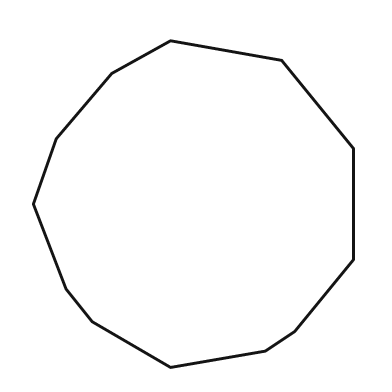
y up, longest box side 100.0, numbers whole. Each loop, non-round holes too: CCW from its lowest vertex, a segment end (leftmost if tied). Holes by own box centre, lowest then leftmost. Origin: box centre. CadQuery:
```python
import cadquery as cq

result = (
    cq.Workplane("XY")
    .moveTo(-7.0, -50.0)
    .lineTo(22.0, -45.0)
    .lineTo(31.0, -39.0)
    .lineTo(49.0, -17.0)
    .lineTo(49.0, 17.0)
    .lineTo(27.0, 44.0)
    .lineTo(-7.0, 50.0)
    .lineTo(-25.0, 40.0)
    .lineTo(-42.0, 20.0)
    .lineTo(-49.0, 0.0)
    .lineTo(-39.0, -26.0)
    .lineTo(-31.0, -36.0)
    .close()
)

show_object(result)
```